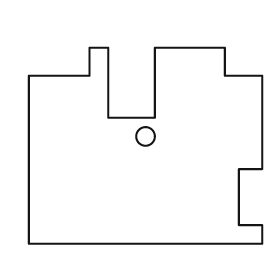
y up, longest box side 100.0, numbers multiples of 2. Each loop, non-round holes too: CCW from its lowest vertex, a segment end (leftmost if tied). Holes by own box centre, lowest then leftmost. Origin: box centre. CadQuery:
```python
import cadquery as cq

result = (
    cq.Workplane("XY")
    .moveTo(-50.0, -42.0)
    .lineTo(50.0, -42.0)
    .lineTo(50.0, -34.0)
    .lineTo(40.0, -34.0)
    .lineTo(40.0, -10.0)
    .lineTo(50.0, -10.0)
    .lineTo(50.0, 30.0)
    .lineTo(34.0, 30.0)
    .lineTo(34.0, 42.0)
    .lineTo(4.0, 42.0)
    .lineTo(4.0, 12.0)
    .lineTo(-16.0, 12.0)
    .lineTo(-16.0, 42.0)
    .lineTo(-24.0, 42.0)
    .lineTo(-24.0, 30.0)
    .lineTo(-50.0, 30.0)
    .close()
    .moveTo(0.0, 4.0)
    .circle(4.0)
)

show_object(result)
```